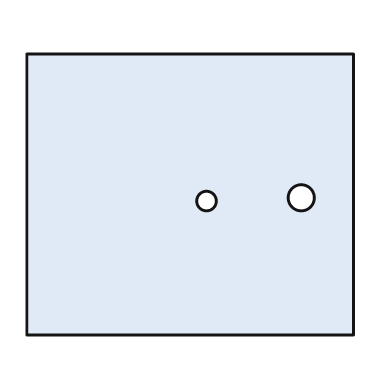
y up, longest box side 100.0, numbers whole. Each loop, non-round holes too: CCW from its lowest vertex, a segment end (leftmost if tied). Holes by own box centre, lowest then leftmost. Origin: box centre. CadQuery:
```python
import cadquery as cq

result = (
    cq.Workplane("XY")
    .moveTo(-50.0, -43.0)
    .lineTo(50.0, -43.0)
    .lineTo(50.0, 43.0)
    .lineTo(-50.0, 43.0)
    .close()
    .moveTo(5.0, -2.0)
    .circle(3.0)
    .moveTo(34.0, -1.0)
    .circle(4.0)
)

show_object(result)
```